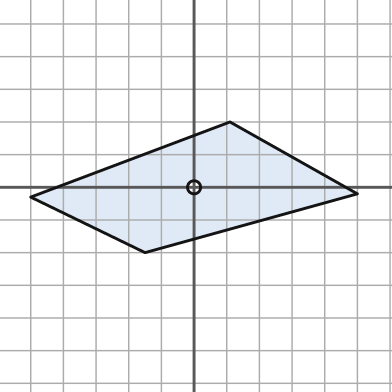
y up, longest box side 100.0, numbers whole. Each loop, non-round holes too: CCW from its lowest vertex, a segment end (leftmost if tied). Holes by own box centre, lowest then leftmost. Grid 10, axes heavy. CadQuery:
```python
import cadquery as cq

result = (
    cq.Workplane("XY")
    .moveTo(-15.0, -20.0)
    .lineTo(50.0, -2.0)
    .lineTo(11.0, 20.0)
    .lineTo(-50.0, -3.0)
    .close()
    .moveTo(0.0, 0.0)
    .circle(2.0)
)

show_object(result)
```